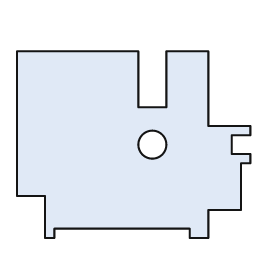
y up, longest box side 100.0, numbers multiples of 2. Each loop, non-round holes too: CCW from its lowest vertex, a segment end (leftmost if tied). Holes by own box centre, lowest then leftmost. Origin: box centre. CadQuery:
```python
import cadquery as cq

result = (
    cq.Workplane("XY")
    .moveTo(-38.0, -40.0)
    .lineTo(-34.0, -40.0)
    .lineTo(-34.0, -36.0)
    .lineTo(24.0, -36.0)
    .lineTo(24.0, -40.0)
    .lineTo(32.0, -40.0)
    .lineTo(32.0, -28.0)
    .lineTo(46.0, -28.0)
    .lineTo(46.0, -8.0)
    .lineTo(50.0, -8.0)
    .lineTo(50.0, -4.0)
    .lineTo(42.0, -4.0)
    .lineTo(42.0, 4.0)
    .lineTo(50.0, 4.0)
    .lineTo(50.0, 8.0)
    .lineTo(32.0, 8.0)
    .lineTo(32.0, 40.0)
    .lineTo(14.0, 40.0)
    .lineTo(14.0, 16.0)
    .lineTo(2.0, 16.0)
    .lineTo(2.0, 40.0)
    .lineTo(-50.0, 40.0)
    .lineTo(-50.0, -22.0)
    .lineTo(-38.0, -22.0)
    .close()
    .moveTo(8.0, 0.0)
    .circle(6.0)
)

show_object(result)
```